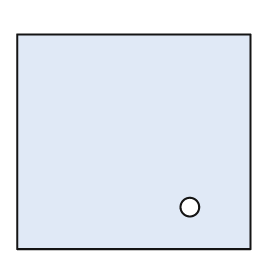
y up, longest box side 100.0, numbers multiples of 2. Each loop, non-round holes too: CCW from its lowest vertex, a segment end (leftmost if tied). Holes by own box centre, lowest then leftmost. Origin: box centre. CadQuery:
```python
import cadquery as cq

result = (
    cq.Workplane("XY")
    .moveTo(-50.0, -46.0)
    .lineTo(50.0, -46.0)
    .lineTo(50.0, 46.0)
    .lineTo(-50.0, 46.0)
    .close()
    .moveTo(24.0, -28.0)
    .circle(4.0)
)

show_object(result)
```